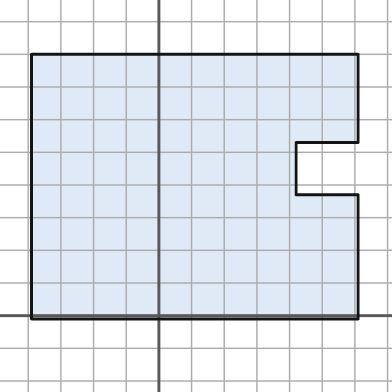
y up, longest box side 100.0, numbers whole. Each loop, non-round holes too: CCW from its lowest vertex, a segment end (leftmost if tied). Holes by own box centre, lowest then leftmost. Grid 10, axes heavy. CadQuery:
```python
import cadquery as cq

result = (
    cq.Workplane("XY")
    .moveTo(-39.0, -1.0)
    .lineTo(61.0, -1.0)
    .lineTo(61.0, 37.0)
    .lineTo(42.0, 37.0)
    .lineTo(42.0, 53.0)
    .lineTo(61.0, 53.0)
    .lineTo(61.0, 80.0)
    .lineTo(-39.0, 80.0)
    .close()
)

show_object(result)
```